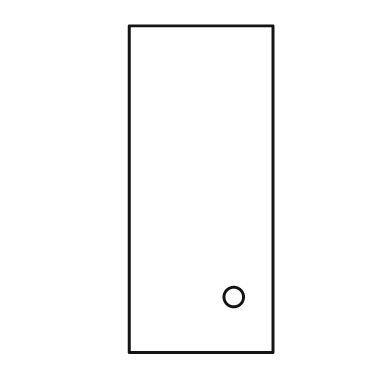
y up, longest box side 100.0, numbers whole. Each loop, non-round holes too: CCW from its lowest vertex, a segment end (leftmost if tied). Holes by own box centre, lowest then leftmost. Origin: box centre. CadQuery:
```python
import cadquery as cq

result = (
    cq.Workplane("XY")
    .moveTo(-22.0, -50.0)
    .lineTo(22.0, -50.0)
    .lineTo(22.0, 50.0)
    .lineTo(-22.0, 50.0)
    .close()
    .moveTo(10.0, -33.0)
    .circle(3.0)
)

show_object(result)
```